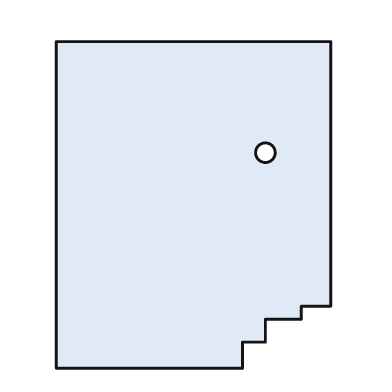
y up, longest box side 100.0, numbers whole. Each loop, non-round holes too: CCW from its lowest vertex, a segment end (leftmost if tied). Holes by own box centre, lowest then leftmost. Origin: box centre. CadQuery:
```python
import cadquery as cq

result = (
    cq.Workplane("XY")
    .moveTo(-42.0, -50.0)
    .lineTo(15.0, -50.0)
    .lineTo(15.0, -42.0)
    .lineTo(22.0, -42.0)
    .lineTo(22.0, -35.0)
    .lineTo(33.0, -35.0)
    .lineTo(33.0, -31.0)
    .lineTo(42.0, -31.0)
    .lineTo(42.0, 50.0)
    .lineTo(-42.0, 50.0)
    .close()
    .moveTo(22.0, 16.0)
    .circle(3.0)
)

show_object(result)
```